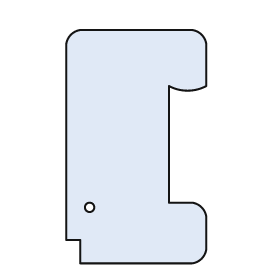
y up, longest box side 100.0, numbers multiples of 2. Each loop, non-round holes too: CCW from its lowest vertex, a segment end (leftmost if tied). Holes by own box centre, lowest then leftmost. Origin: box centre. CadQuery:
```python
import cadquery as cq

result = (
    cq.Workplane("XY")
    .moveTo(-24.0, -50.0)
    .lineTo(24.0, -50.0)
    .threePointArc((28.0, -48.0), (30.0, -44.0))
    .lineTo(30.0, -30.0)
    .threePointArc((28.0, -26.0), (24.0, -24.0))
    .lineTo(14.0, -24.0)
    .lineTo(14.0, 26.0)
    .threePointArc((22.0, 24.0), (30.0, 26.0))
    .lineTo(30.0, 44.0)
    .threePointArc((28.0, 48.0), (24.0, 50.0))
    .lineTo(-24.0, 50.0)
    .threePointArc((-28.0, 48.0), (-30.0, 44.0))
    .lineTo(-30.0, -40.0)
    .lineTo(-24.0, -40.0)
    .close()
    .moveTo(-20.0, -26.0)
    .circle(2.0)
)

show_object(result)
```